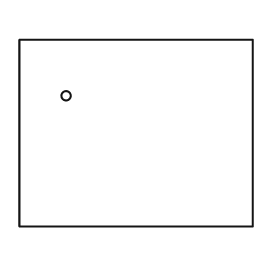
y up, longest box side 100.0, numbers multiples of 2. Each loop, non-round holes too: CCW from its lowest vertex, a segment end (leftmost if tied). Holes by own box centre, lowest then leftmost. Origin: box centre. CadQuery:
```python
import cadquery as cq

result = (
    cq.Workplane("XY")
    .moveTo(-50.0, -40.0)
    .lineTo(50.0, -40.0)
    .lineTo(50.0, 40.0)
    .lineTo(-50.0, 40.0)
    .close()
    .moveTo(-30.0, 16.0)
    .circle(2.0)
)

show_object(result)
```